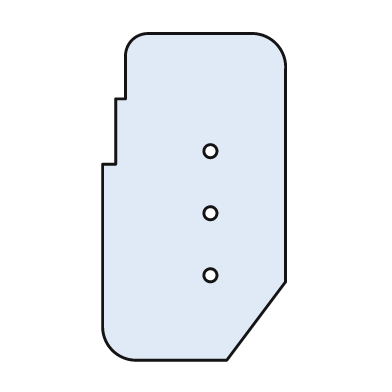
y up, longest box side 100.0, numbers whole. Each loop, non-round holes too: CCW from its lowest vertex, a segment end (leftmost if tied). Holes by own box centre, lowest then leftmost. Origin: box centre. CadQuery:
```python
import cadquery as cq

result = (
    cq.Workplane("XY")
    .moveTo(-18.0, -50.0)
    .lineTo(10.0, -50.0)
    .lineTo(28.0, -26.0)
    .lineTo(28.0, 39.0)
    .threePointArc((25.0, 47.0), (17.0, 50.0))
    .lineTo(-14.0, 50.0)
    .threePointArc((-19.0, 48.0), (-21.0, 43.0))
    .lineTo(-21.0, 30.0)
    .lineTo(-24.0, 30.0)
    .lineTo(-24.0, 10.0)
    .lineTo(-28.0, 10.0)
    .lineTo(-28.0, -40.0)
    .threePointArc((-25.0, -47.0), (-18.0, -50.0))
    .close()
    .moveTo(5.0, -24.0)
    .circle(2.0)
    .moveTo(5.0, -5.0)
    .circle(2.0)
    .moveTo(5.0, 14.0)
    .circle(2.0)
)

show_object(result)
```